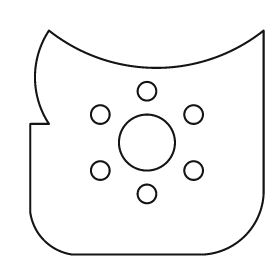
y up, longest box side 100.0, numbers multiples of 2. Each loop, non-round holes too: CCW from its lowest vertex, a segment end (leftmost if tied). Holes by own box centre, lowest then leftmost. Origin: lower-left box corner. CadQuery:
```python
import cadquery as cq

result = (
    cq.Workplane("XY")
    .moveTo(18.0, 0.0)
    .lineTo(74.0, 0.0)
    .threePointArc((92.0, 8.0), (100.0, 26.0))
    .lineTo(100.0, 96.0)
    .threePointArc((54.0, 80.0), (8.0, 96.0))
    .threePointArc((2.0, 76.0), (8.0, 56.0))
    .lineTo(0.0, 56.0)
    .lineTo(0.0, 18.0)
    .threePointArc((6.0, 6.0), (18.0, 0.0))
    .close()
    .moveTo(50.0, 26.0)
    .circle(4.0)
    .moveTo(30.0, 36.0)
    .circle(4.0)
    .moveTo(70.0, 36.0)
    .circle(4.0)
    .moveTo(50.0, 48.0)
    .circle(12.0)
    .moveTo(30.0, 60.0)
    .circle(4.0)
    .moveTo(70.0, 60.0)
    .circle(4.0)
    .moveTo(50.0, 70.0)
    .circle(4.0)
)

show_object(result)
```